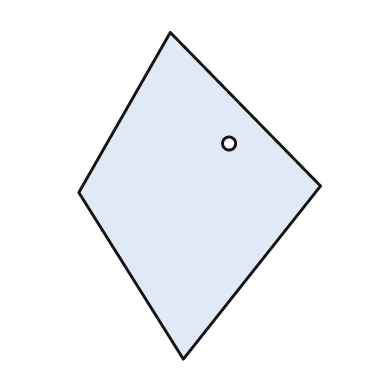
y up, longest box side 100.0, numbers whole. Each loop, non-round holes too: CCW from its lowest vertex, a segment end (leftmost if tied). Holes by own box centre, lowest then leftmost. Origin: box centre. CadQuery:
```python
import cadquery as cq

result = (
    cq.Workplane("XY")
    .moveTo(-5.0, -50.0)
    .lineTo(37.0, 3.0)
    .lineTo(-9.0, 50.0)
    .lineTo(-37.0, 1.0)
    .close()
    .moveTo(9.0, 16.0)
    .circle(2.0)
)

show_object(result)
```